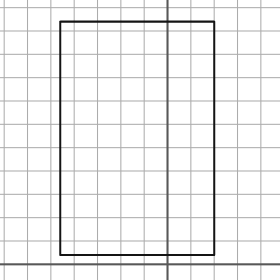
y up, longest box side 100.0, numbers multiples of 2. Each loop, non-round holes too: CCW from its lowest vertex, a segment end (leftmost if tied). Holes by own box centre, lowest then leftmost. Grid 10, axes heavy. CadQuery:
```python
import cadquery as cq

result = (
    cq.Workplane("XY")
    .moveTo(-46.0, 4.0)
    .lineTo(20.0, 4.0)
    .lineTo(20.0, 104.0)
    .lineTo(-46.0, 104.0)
    .close()
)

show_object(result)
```